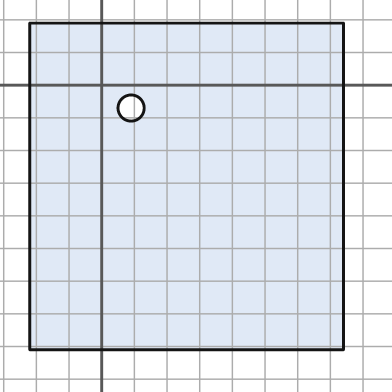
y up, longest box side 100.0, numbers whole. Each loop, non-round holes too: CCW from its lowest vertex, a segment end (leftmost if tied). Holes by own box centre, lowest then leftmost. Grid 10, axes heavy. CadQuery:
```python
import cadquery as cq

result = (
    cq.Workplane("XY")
    .moveTo(-22.0, -81.0)
    .lineTo(74.0, -81.0)
    .lineTo(74.0, 19.0)
    .lineTo(-22.0, 19.0)
    .close()
    .moveTo(9.0, -7.0)
    .circle(4.0)
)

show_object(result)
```